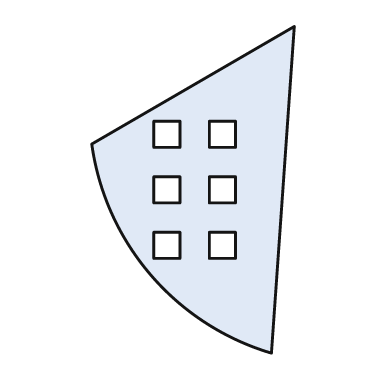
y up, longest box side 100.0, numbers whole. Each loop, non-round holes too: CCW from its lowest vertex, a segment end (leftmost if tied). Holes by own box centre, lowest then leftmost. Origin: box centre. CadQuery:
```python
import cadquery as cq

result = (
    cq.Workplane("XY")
    .moveTo(24.0, -50.0)
    .lineTo(31.0, 50.0)
    .lineTo(-31.0, 14.0)
    .threePointArc((-13.0, -26.0), (24.0, -50.0))
    .close()
    .moveTo(-12.0, -21.0)
    .lineTo(-4.0, -21.0)
    .lineTo(-4.0, -13.0)
    .lineTo(-12.0, -13.0)
    .close()
    .moveTo(5.0, -21.0)
    .lineTo(13.0, -21.0)
    .lineTo(13.0, -13.0)
    .lineTo(5.0, -13.0)
    .close()
    .moveTo(-12.0, -4.0)
    .lineTo(-4.0, -4.0)
    .lineTo(-4.0, 4.0)
    .lineTo(-12.0, 4.0)
    .close()
    .moveTo(5.0, -4.0)
    .lineTo(13.0, -4.0)
    .lineTo(13.0, 4.0)
    .lineTo(5.0, 4.0)
    .close()
    .moveTo(-12.0, 13.0)
    .lineTo(-4.0, 13.0)
    .lineTo(-4.0, 21.0)
    .lineTo(-12.0, 21.0)
    .close()
    .moveTo(5.0, 13.0)
    .lineTo(13.0, 13.0)
    .lineTo(13.0, 21.0)
    .lineTo(5.0, 21.0)
    .close()
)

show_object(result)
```